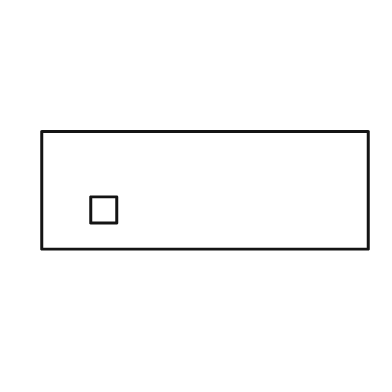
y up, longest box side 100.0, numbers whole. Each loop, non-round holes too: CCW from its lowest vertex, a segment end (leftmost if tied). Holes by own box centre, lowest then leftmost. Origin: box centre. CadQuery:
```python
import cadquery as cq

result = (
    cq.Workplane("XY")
    .moveTo(-50.0, -18.0)
    .lineTo(50.0, -18.0)
    .lineTo(50.0, 18.0)
    .lineTo(-50.0, 18.0)
    .close()
    .moveTo(-35.0, -10.0)
    .lineTo(-27.0, -10.0)
    .lineTo(-27.0, -2.0)
    .lineTo(-35.0, -2.0)
    .close()
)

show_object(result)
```